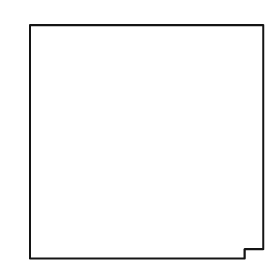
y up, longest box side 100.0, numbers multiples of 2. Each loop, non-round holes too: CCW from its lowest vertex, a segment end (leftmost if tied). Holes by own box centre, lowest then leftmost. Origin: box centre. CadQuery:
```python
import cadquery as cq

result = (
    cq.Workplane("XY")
    .moveTo(-50.0, -50.0)
    .lineTo(42.0, -50.0)
    .lineTo(42.0, -46.0)
    .lineTo(50.0, -46.0)
    .lineTo(50.0, 50.0)
    .lineTo(-50.0, 50.0)
    .close()
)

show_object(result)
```